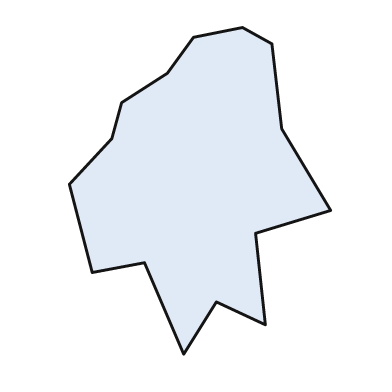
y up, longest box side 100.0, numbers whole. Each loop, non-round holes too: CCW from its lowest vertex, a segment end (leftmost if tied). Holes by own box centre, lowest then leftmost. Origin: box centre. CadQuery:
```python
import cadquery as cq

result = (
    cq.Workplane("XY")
    .moveTo(-5.0, -50.0)
    .lineTo(5.0, -34.0)
    .lineTo(20.0, -41.0)
    .lineTo(17.0, -13.0)
    .lineTo(40.0, -6.0)
    .lineTo(25.0, 19.0)
    .lineTo(22.0, 45.0)
    .lineTo(13.0, 50.0)
    .lineTo(-2.0, 47.0)
    .lineTo(-10.0, 36.0)
    .lineTo(-24.0, 27.0)
    .lineTo(-27.0, 16.0)
    .lineTo(-40.0, 2.0)
    .lineTo(-33.0, -25.0)
    .lineTo(-17.0, -22.0)
    .close()
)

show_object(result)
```